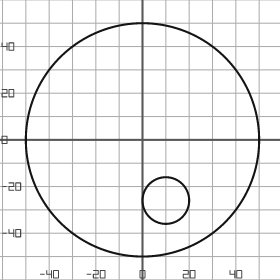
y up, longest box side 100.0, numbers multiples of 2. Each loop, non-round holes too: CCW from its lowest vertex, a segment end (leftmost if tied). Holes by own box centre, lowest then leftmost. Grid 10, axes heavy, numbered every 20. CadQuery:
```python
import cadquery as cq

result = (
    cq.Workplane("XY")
    .moveTo(0.0, 0.0)
    .circle(50.0)
    .moveTo(10.0, -26.0)
    .circle(10.0)
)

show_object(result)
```